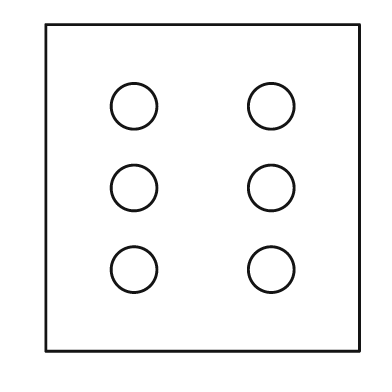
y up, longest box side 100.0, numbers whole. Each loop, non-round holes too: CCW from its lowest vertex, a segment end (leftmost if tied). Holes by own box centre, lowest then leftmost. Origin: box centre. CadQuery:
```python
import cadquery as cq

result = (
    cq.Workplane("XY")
    .moveTo(-48.0, -50.0)
    .lineTo(48.0, -50.0)
    .lineTo(48.0, 50.0)
    .lineTo(-48.0, 50.0)
    .close()
    .moveTo(-21.0, -25.0)
    .circle(7.0)
    .moveTo(21.0, -25.0)
    .circle(7.0)
    .moveTo(-21.0, 0.0)
    .circle(7.0)
    .moveTo(21.0, 0.0)
    .circle(7.0)
    .moveTo(-21.0, 25.0)
    .circle(7.0)
    .moveTo(21.0, 25.0)
    .circle(7.0)
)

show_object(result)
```